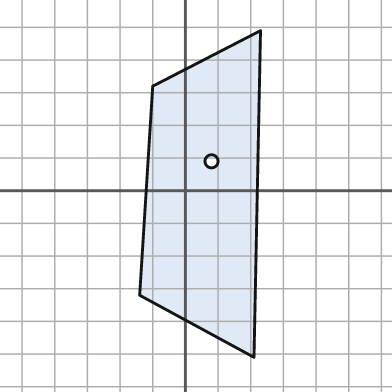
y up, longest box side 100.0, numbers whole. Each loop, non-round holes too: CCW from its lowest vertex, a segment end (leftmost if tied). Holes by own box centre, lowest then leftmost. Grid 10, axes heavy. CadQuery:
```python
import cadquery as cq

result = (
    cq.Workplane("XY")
    .moveTo(21.0, -51.0)
    .lineTo(23.0, 49.0)
    .lineTo(-10.0, 32.0)
    .lineTo(-14.0, -32.0)
    .close()
    .moveTo(8.0, 9.0)
    .circle(2.0)
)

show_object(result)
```